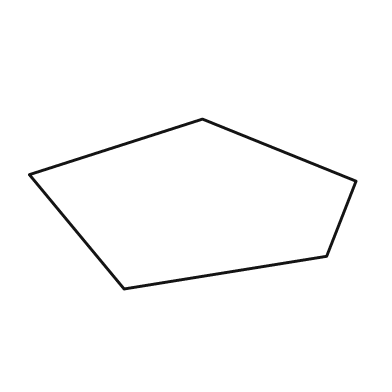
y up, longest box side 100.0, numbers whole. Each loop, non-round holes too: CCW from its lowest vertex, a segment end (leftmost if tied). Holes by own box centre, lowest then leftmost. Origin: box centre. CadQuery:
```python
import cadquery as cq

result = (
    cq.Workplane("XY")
    .moveTo(-21.0, -26.0)
    .lineTo(41.0, -16.0)
    .lineTo(50.0, 7.0)
    .lineTo(3.0, 26.0)
    .lineTo(-50.0, 9.0)
    .close()
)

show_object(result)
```